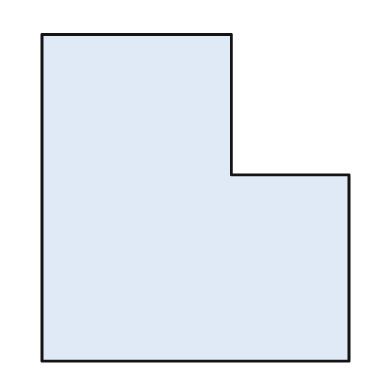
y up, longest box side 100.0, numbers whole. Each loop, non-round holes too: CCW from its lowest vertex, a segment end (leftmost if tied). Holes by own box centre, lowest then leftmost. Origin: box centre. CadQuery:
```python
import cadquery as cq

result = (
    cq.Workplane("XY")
    .moveTo(-47.0, -50.0)
    .lineTo(47.0, -50.0)
    .lineTo(47.0, 7.0)
    .lineTo(11.0, 7.0)
    .lineTo(11.0, 50.0)
    .lineTo(-47.0, 50.0)
    .close()
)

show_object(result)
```